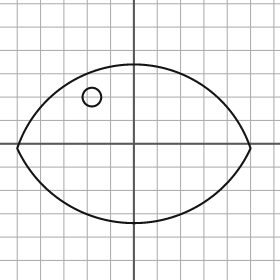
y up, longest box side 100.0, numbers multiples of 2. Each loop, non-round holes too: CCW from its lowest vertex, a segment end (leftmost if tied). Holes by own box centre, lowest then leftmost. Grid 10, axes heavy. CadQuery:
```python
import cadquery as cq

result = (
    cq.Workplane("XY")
    .moveTo(-50.0, -2.0)
    .threePointArc((0.0, -34.0), (50.0, -2.0))
    .threePointArc((0.0, 34.0), (-50.0, -2.0))
    .close()
    .moveTo(-18.0, 20.0)
    .circle(4.0)
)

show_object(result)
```